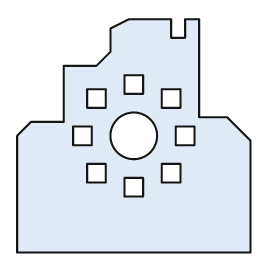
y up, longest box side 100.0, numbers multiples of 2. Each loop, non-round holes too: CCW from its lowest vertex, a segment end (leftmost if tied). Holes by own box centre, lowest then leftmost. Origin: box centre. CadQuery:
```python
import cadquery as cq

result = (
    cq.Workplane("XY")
    .moveTo(-50.0, -50.0)
    .lineTo(50.0, -50.0)
    .lineTo(50.0, -2.0)
    .lineTo(40.0, 8.0)
    .lineTo(28.0, 8.0)
    .lineTo(28.0, 50.0)
    .lineTo(22.0, 50.0)
    .lineTo(22.0, 42.0)
    .lineTo(16.0, 42.0)
    .lineTo(16.0, 50.0)
    .lineTo(-2.0, 50.0)
    .lineTo(-10.0, 46.0)
    .lineTo(-10.0, 36.0)
    .lineTo(-16.0, 30.0)
    .lineTo(-30.0, 30.0)
    .lineTo(-30.0, 6.0)
    .lineTo(-44.0, 6.0)
    .lineTo(-50.0, 0.0)
    .close()
    .moveTo(-4.0, -26.0)
    .lineTo(4.0, -26.0)
    .lineTo(4.0, -18.0)
    .lineTo(-4.0, -18.0)
    .close()
    .moveTo(-20.0, -20.0)
    .lineTo(-12.0, -20.0)
    .lineTo(-12.0, -12.0)
    .lineTo(-20.0, -12.0)
    .close()
    .moveTo(12.0, -20.0)
    .lineTo(20.0, -20.0)
    .lineTo(20.0, -12.0)
    .lineTo(12.0, -12.0)
    .close()
    .moveTo(-26.0, -4.0)
    .lineTo(-18.0, -4.0)
    .lineTo(-18.0, 4.0)
    .lineTo(-26.0, 4.0)
    .close()
    .moveTo(0.0, 0.0)
    .circle(10.0)
    .moveTo(18.0, -4.0)
    .lineTo(26.0, -4.0)
    .lineTo(26.0, 4.0)
    .lineTo(18.0, 4.0)
    .close()
    .moveTo(-20.0, 12.0)
    .lineTo(-12.0, 12.0)
    .lineTo(-12.0, 20.0)
    .lineTo(-20.0, 20.0)
    .close()
    .moveTo(12.0, 12.0)
    .lineTo(20.0, 12.0)
    .lineTo(20.0, 20.0)
    .lineTo(12.0, 20.0)
    .close()
    .moveTo(-4.0, 18.0)
    .lineTo(4.0, 18.0)
    .lineTo(4.0, 26.0)
    .lineTo(-4.0, 26.0)
    .close()
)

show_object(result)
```